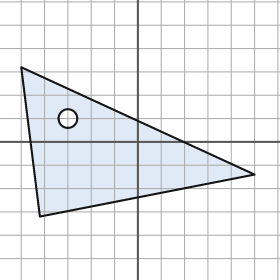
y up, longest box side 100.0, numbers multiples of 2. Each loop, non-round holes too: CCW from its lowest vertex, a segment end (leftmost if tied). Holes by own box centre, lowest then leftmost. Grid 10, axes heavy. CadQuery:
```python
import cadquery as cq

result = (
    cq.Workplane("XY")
    .moveTo(-42.0, -32.0)
    .lineTo(50.0, -14.0)
    .lineTo(-50.0, 32.0)
    .close()
    .moveTo(-30.0, 10.0)
    .circle(4.0)
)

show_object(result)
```